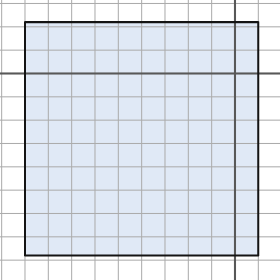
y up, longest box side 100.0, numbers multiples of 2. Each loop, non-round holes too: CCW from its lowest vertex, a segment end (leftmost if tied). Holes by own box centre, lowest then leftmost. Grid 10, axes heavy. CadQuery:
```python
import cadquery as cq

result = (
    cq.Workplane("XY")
    .moveTo(-90.0, -78.0)
    .lineTo(10.0, -78.0)
    .lineTo(10.0, 22.0)
    .lineTo(-90.0, 22.0)
    .close()
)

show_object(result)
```